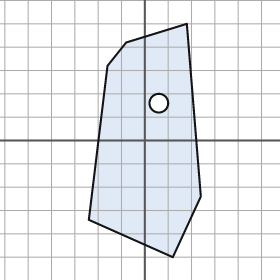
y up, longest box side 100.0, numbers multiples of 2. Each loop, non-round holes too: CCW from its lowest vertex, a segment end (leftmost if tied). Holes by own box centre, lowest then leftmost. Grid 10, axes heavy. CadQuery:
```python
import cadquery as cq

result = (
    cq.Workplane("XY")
    .moveTo(12.0, -50.0)
    .lineTo(24.0, -24.0)
    .lineTo(18.0, 50.0)
    .lineTo(-8.0, 42.0)
    .lineTo(-16.0, 32.0)
    .lineTo(-24.0, -34.0)
    .close()
    .moveTo(6.0, 16.0)
    .circle(4.0)
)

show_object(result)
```